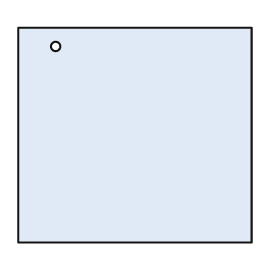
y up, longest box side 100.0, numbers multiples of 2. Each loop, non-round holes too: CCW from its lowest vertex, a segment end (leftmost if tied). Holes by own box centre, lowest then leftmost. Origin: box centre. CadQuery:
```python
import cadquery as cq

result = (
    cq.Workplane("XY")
    .moveTo(-50.0, -46.0)
    .lineTo(50.0, -46.0)
    .lineTo(50.0, 46.0)
    .lineTo(-50.0, 46.0)
    .close()
    .moveTo(-34.0, 38.0)
    .circle(2.0)
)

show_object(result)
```